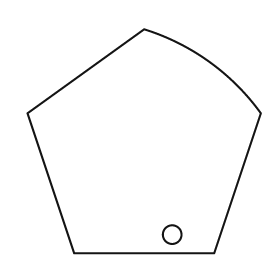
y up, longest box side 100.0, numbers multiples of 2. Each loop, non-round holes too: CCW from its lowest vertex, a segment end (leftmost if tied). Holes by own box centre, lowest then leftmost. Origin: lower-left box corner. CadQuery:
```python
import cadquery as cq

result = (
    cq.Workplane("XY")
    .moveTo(20.0, 0.0)
    .lineTo(80.0, 0.0)
    .lineTo(100.0, 60.0)
    .threePointArc((78.0, 82.0), (50.0, 96.0))
    .lineTo(0.0, 60.0)
    .close()
    .moveTo(62.0, 8.0)
    .circle(4.0)
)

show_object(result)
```